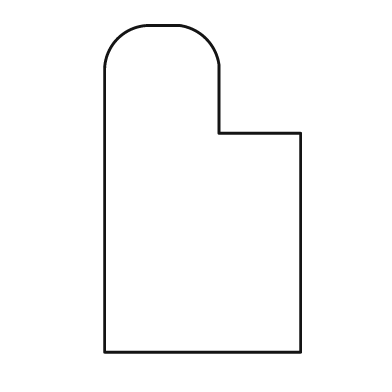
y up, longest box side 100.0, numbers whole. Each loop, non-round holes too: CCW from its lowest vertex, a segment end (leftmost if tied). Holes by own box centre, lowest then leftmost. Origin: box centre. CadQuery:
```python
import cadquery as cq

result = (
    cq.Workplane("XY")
    .moveTo(-30.0, -50.0)
    .lineTo(30.0, -50.0)
    .lineTo(30.0, 17.0)
    .lineTo(5.0, 17.0)
    .lineTo(5.0, 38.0)
    .threePointArc((1.0, 46.0), (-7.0, 50.0))
    .lineTo(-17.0, 50.0)
    .threePointArc((-26.0, 46.0), (-30.0, 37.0))
    .close()
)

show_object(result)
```